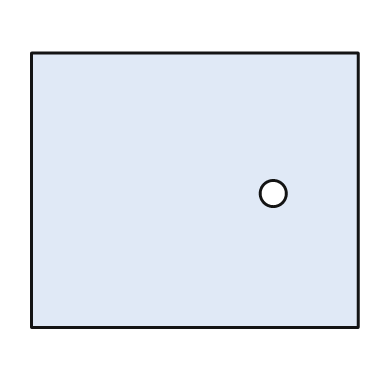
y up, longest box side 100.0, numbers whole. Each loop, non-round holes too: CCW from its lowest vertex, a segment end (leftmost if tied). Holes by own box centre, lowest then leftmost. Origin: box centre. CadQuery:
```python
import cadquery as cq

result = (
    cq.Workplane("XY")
    .moveTo(-50.0, -42.0)
    .lineTo(50.0, -42.0)
    .lineTo(50.0, 42.0)
    .lineTo(-50.0, 42.0)
    .close()
    .moveTo(24.0, -1.0)
    .circle(4.0)
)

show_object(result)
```